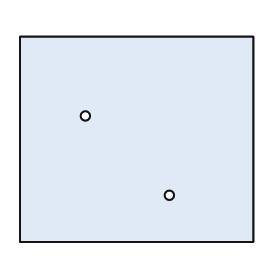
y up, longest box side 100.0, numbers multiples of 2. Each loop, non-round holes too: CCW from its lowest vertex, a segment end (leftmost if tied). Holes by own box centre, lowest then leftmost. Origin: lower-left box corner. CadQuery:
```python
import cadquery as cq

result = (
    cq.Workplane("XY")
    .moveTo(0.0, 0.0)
    .lineTo(100.0, 0.0)
    .lineTo(100.0, 88.0)
    .lineTo(0.0, 88.0)
    .close()
    .moveTo(64.0, 20.0)
    .circle(2.0)
    .moveTo(28.0, 54.0)
    .circle(2.0)
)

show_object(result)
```